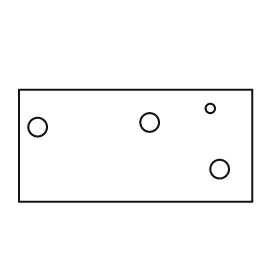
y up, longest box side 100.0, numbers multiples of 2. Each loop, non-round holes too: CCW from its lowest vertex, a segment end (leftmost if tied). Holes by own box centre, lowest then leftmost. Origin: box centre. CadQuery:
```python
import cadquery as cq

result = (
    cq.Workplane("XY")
    .moveTo(-50.0, -24.0)
    .lineTo(50.0, -24.0)
    .lineTo(50.0, 24.0)
    .lineTo(-50.0, 24.0)
    .close()
    .moveTo(36.0, -10.0)
    .circle(4.0)
    .moveTo(-42.0, 8.0)
    .circle(4.0)
    .moveTo(6.0, 10.0)
    .circle(4.0)
    .moveTo(32.0, 16.0)
    .circle(2.0)
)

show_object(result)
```